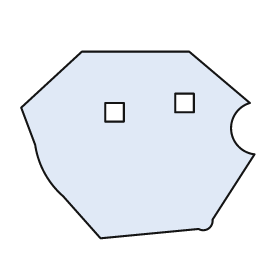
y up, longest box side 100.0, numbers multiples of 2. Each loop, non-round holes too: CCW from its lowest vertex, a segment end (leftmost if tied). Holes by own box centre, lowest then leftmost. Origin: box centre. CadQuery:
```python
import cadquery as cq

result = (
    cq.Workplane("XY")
    .moveTo(-16.0, -40.0)
    .lineTo(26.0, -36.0)
    .threePointArc((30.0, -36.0), (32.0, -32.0))
    .lineTo(50.0, -4.0)
    .threePointArc((40.0, 6.0), (48.0, 18.0))
    .lineTo(22.0, 40.0)
    .lineTo(-24.0, 40.0)
    .lineTo(-50.0, 16.0)
    .lineTo(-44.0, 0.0)
    .threePointArc((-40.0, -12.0), (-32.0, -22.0))
    .close()
    .moveTo(-14.0, 10.0)
    .lineTo(-6.0, 10.0)
    .lineTo(-6.0, 18.0)
    .lineTo(-14.0, 18.0)
    .close()
    .moveTo(16.0, 14.0)
    .lineTo(24.0, 14.0)
    .lineTo(24.0, 22.0)
    .lineTo(16.0, 22.0)
    .close()
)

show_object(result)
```